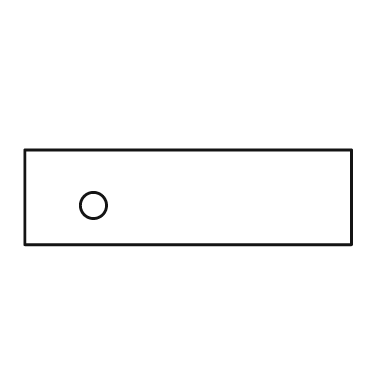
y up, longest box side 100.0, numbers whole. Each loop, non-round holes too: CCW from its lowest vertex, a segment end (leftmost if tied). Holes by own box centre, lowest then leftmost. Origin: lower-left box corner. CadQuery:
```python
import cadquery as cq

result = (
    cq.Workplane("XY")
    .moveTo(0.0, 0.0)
    .lineTo(100.0, 0.0)
    .lineTo(100.0, 29.0)
    .lineTo(0.0, 29.0)
    .close()
    .moveTo(21.0, 12.0)
    .circle(4.0)
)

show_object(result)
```